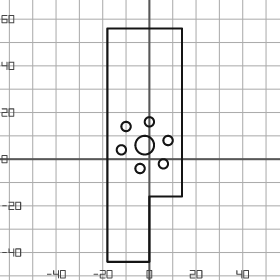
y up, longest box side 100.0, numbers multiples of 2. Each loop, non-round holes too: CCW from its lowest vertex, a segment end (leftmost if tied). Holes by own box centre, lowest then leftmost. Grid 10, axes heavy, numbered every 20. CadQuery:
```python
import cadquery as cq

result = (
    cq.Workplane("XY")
    .moveTo(-18.0, -44.0)
    .lineTo(0.0, -44.0)
    .lineTo(0.0, -16.0)
    .lineTo(14.0, -16.0)
    .lineTo(14.0, 56.0)
    .lineTo(-18.0, 56.0)
    .close()
    .moveTo(-4.0, -4.0)
    .circle(2.0)
    .moveTo(6.0, -2.0)
    .circle(2.0)
    .moveTo(-12.0, 4.0)
    .circle(2.0)
    .moveTo(-2.0, 6.0)
    .circle(4.0)
    .moveTo(8.0, 8.0)
    .circle(2.0)
    .moveTo(-10.0, 14.0)
    .circle(2.0)
    .moveTo(0.0, 16.0)
    .circle(2.0)
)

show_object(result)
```